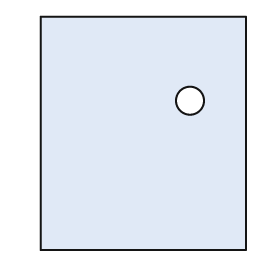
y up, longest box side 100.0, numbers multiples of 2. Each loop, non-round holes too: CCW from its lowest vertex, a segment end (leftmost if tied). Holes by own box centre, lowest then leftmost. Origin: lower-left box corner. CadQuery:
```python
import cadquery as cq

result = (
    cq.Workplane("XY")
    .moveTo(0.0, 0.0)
    .lineTo(88.0, 0.0)
    .lineTo(88.0, 100.0)
    .lineTo(0.0, 100.0)
    .close()
    .moveTo(64.0, 64.0)
    .circle(6.0)
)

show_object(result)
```